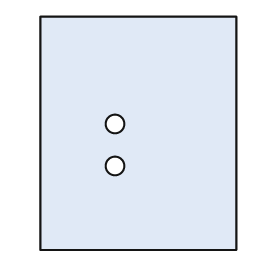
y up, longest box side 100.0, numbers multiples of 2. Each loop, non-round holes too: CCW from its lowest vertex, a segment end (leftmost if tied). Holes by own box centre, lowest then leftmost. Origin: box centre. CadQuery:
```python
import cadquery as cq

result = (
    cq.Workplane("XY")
    .moveTo(-42.0, -50.0)
    .lineTo(42.0, -50.0)
    .lineTo(42.0, 50.0)
    .lineTo(-42.0, 50.0)
    .close()
    .moveTo(-10.0, -14.0)
    .circle(4.0)
    .moveTo(-10.0, 4.0)
    .circle(4.0)
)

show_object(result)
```